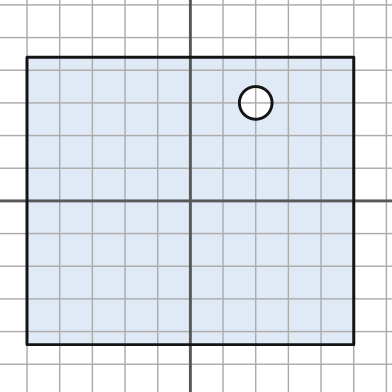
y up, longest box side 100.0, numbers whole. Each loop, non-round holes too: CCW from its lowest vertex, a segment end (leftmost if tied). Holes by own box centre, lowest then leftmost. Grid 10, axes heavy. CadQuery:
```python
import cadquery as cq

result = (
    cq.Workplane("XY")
    .moveTo(-50.0, -44.0)
    .lineTo(50.0, -44.0)
    .lineTo(50.0, 44.0)
    .lineTo(-50.0, 44.0)
    .close()
    .moveTo(20.0, 30.0)
    .circle(5.0)
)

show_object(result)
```